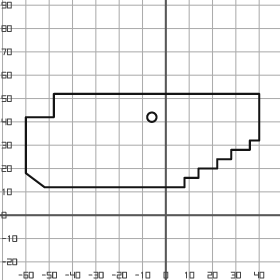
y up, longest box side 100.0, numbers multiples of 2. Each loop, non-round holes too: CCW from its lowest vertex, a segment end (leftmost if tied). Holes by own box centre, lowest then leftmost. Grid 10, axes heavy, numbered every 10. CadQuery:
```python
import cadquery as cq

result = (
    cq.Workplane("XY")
    .moveTo(-52.0, 12.0)
    .lineTo(8.0, 12.0)
    .lineTo(8.0, 16.0)
    .lineTo(14.0, 16.0)
    .lineTo(14.0, 20.0)
    .lineTo(22.0, 20.0)
    .lineTo(22.0, 24.0)
    .lineTo(28.0, 24.0)
    .lineTo(28.0, 28.0)
    .lineTo(36.0, 28.0)
    .lineTo(36.0, 32.0)
    .lineTo(40.0, 32.0)
    .lineTo(40.0, 52.0)
    .lineTo(-48.0, 52.0)
    .lineTo(-48.0, 42.0)
    .lineTo(-60.0, 42.0)
    .lineTo(-60.0, 18.0)
    .close()
    .moveTo(-6.0, 42.0)
    .circle(2.0)
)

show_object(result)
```